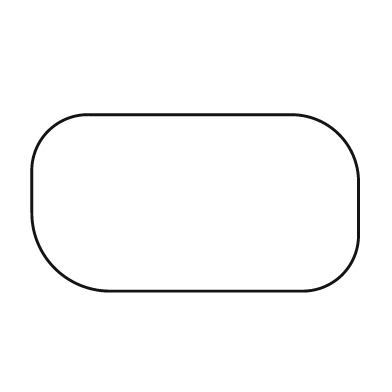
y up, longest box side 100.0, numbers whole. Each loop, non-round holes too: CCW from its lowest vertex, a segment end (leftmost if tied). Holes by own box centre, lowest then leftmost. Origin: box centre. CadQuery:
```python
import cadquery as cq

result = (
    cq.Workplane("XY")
    .moveTo(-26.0, -27.0)
    .lineTo(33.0, -27.0)
    .threePointArc((45.0, -22.0), (50.0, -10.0))
    .lineTo(50.0, 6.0)
    .threePointArc((44.0, 21.0), (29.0, 27.0))
    .lineTo(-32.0, 27.0)
    .threePointArc((-45.0, 22.0), (-50.0, 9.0))
    .lineTo(-50.0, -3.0)
    .threePointArc((-43.0, -20.0), (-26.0, -27.0))
    .close()
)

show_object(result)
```